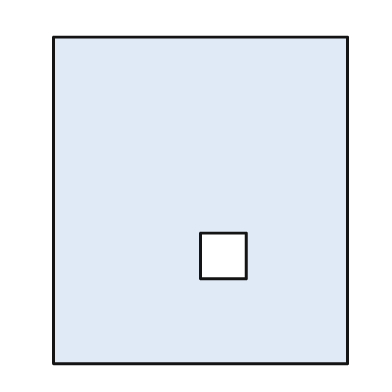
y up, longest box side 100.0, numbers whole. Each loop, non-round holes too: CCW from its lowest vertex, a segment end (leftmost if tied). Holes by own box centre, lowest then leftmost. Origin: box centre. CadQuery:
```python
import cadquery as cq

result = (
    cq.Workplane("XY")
    .moveTo(-45.0, -50.0)
    .lineTo(45.0, -50.0)
    .lineTo(45.0, 50.0)
    .lineTo(-45.0, 50.0)
    .close()
    .moveTo(0.0, -24.0)
    .lineTo(14.0, -24.0)
    .lineTo(14.0, -10.0)
    .lineTo(0.0, -10.0)
    .close()
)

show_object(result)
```